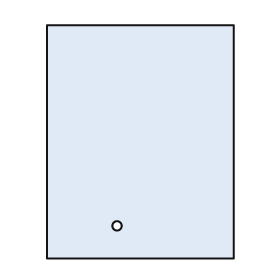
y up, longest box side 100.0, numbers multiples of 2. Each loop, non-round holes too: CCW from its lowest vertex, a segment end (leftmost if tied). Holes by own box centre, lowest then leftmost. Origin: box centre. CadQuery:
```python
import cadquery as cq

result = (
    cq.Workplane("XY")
    .moveTo(-40.0, -50.0)
    .lineTo(40.0, -50.0)
    .lineTo(40.0, 50.0)
    .lineTo(-40.0, 50.0)
    .close()
    .moveTo(-10.0, -36.0)
    .circle(2.0)
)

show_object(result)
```